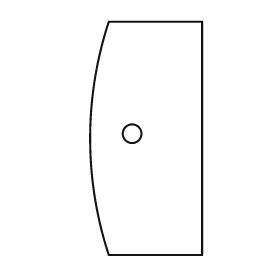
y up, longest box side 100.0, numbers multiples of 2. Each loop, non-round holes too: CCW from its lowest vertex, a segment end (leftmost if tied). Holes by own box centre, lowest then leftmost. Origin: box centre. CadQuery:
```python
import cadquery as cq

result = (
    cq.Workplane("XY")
    .moveTo(-16.0, -50.0)
    .lineTo(24.0, -50.0)
    .lineTo(24.0, 50.0)
    .lineTo(-16.0, 50.0)
    .threePointArc((-24.0, 0.0), (-16.0, -50.0))
    .close()
    .moveTo(-6.0, 2.0)
    .circle(4.0)
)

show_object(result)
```